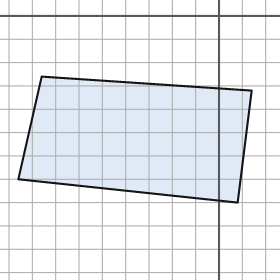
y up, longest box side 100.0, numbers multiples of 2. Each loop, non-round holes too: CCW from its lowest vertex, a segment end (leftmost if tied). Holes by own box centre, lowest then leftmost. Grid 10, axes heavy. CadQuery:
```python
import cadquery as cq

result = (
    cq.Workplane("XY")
    .moveTo(8.0, -80.0)
    .lineTo(14.0, -32.0)
    .lineTo(-76.0, -26.0)
    .lineTo(-86.0, -70.0)
    .close()
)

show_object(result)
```